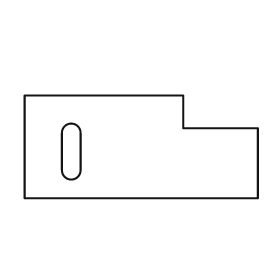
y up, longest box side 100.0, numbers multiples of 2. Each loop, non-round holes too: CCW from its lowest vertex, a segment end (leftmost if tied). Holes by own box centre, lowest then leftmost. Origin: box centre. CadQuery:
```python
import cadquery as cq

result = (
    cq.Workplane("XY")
    .moveTo(-50.0, -22.0)
    .lineTo(50.0, -22.0)
    .lineTo(50.0, 8.0)
    .lineTo(18.0, 8.0)
    .lineTo(18.0, 22.0)
    .lineTo(-50.0, 22.0)
    .close()
    .moveTo(-34.0, -10.0)
    .threePointArc((-30.0, -14.0), (-26.0, -10.0))
    .lineTo(-26.0, 6.0)
    .threePointArc((-30.0, 10.0), (-34.0, 6.0))
    .close()
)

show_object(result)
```